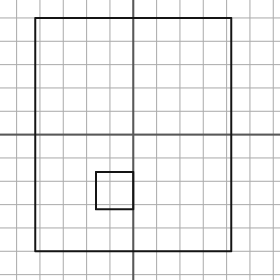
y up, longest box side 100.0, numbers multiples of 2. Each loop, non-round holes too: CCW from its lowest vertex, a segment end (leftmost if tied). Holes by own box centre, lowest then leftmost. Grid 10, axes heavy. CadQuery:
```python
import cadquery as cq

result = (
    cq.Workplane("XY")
    .moveTo(-42.0, -50.0)
    .lineTo(42.0, -50.0)
    .lineTo(42.0, 50.0)
    .lineTo(-42.0, 50.0)
    .close()
    .moveTo(-16.0, -32.0)
    .lineTo(0.0, -32.0)
    .lineTo(0.0, -16.0)
    .lineTo(-16.0, -16.0)
    .close()
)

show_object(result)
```